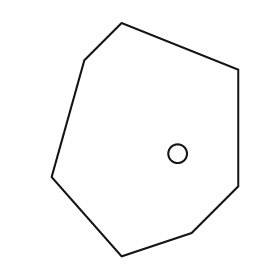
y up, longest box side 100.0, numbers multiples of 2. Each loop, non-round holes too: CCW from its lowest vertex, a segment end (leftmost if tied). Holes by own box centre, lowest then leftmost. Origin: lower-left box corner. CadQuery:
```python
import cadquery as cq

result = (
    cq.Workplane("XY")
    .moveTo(30.0, 0.0)
    .lineTo(60.0, 10.0)
    .lineTo(80.0, 30.0)
    .lineTo(80.0, 80.0)
    .lineTo(30.0, 100.0)
    .lineTo(14.0, 84.0)
    .lineTo(0.0, 34.0)
    .close()
    .moveTo(54.0, 44.0)
    .circle(4.0)
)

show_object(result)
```